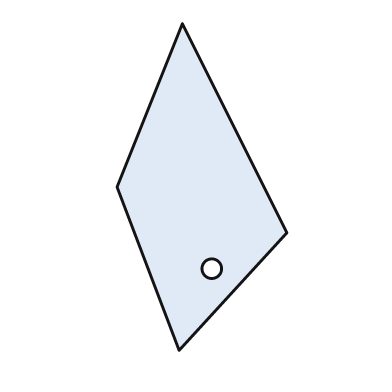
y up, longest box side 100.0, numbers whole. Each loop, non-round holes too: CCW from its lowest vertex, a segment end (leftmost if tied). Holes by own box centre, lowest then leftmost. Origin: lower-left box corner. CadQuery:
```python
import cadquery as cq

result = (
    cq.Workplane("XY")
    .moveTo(19.0, 0.0)
    .lineTo(52.0, 36.0)
    .lineTo(20.0, 100.0)
    .lineTo(0.0, 50.0)
    .close()
    .moveTo(29.0, 25.0)
    .circle(3.0)
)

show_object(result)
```